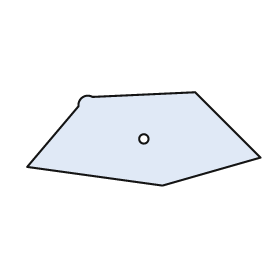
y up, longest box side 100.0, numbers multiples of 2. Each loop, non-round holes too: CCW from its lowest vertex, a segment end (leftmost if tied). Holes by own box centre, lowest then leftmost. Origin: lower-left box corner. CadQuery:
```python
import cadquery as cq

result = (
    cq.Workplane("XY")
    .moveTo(58.0, 0.0)
    .lineTo(100.0, 12.0)
    .lineTo(72.0, 40.0)
    .lineTo(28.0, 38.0)
    .threePointArc((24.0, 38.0), (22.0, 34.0))
    .lineTo(0.0, 8.0)
    .close()
    .moveTo(50.0, 20.0)
    .circle(2.0)
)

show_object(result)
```